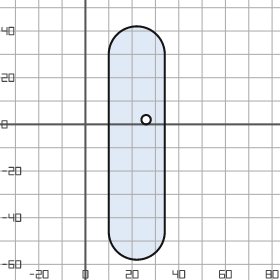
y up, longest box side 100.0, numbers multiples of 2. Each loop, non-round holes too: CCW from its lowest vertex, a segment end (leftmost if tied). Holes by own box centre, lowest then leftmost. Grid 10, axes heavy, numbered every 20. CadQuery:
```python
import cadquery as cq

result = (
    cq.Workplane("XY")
    .moveTo(10.0, -46.0)
    .threePointArc((22.0, -58.0), (34.0, -46.0))
    .lineTo(34.0, 30.0)
    .threePointArc((22.0, 42.0), (10.0, 30.0))
    .close()
    .moveTo(26.0, 2.0)
    .circle(2.0)
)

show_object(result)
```